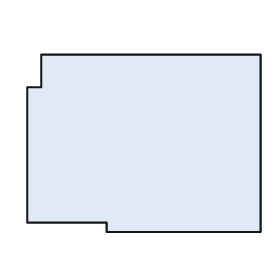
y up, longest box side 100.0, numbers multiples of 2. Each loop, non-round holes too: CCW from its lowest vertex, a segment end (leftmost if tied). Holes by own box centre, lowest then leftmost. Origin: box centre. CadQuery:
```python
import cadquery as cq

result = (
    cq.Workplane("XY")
    .moveTo(-16.0, -38.0)
    .lineTo(50.0, -38.0)
    .lineTo(50.0, 38.0)
    .lineTo(-44.0, 38.0)
    .lineTo(-44.0, 24.0)
    .lineTo(-50.0, 24.0)
    .lineTo(-50.0, -34.0)
    .lineTo(-16.0, -34.0)
    .close()
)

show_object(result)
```